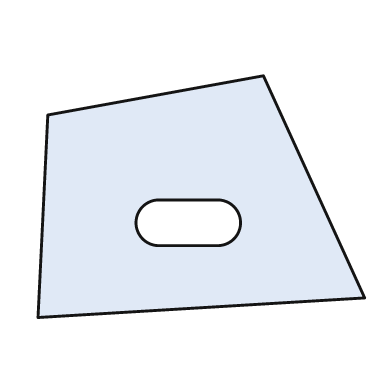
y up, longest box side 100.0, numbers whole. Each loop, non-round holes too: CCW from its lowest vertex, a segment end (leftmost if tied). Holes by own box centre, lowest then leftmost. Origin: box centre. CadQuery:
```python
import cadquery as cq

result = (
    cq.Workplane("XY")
    .moveTo(-50.0, -37.0)
    .lineTo(50.0, -31.0)
    .lineTo(19.0, 37.0)
    .lineTo(-47.0, 25.0)
    .close()
    .moveTo(-13.0, -15.0)
    .lineTo(5.0, -15.0)
    .threePointArc((12.0, -8.0), (5.0, -1.0))
    .lineTo(-13.0, -1.0)
    .threePointArc((-20.0, -8.0), (-13.0, -15.0))
    .close()
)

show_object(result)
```